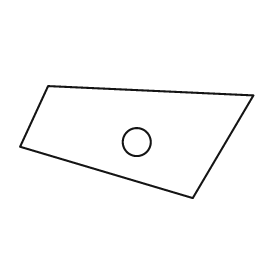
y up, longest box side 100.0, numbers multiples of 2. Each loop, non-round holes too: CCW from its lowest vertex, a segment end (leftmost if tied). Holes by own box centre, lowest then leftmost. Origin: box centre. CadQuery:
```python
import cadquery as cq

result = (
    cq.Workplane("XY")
    .moveTo(24.0, -24.0)
    .lineTo(50.0, 20.0)
    .lineTo(-38.0, 24.0)
    .lineTo(-50.0, -2.0)
    .close()
    .moveTo(0.0, 0.0)
    .circle(6.0)
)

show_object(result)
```